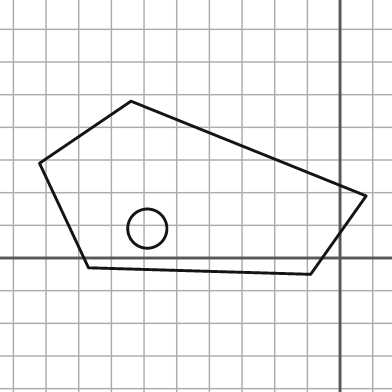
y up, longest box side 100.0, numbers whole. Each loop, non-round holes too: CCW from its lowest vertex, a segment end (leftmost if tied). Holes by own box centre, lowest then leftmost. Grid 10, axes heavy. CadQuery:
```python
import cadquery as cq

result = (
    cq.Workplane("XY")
    .moveTo(-9.0, -5.0)
    .lineTo(8.0, 19.0)
    .lineTo(-64.0, 48.0)
    .lineTo(-92.0, 29.0)
    .lineTo(-77.0, -3.0)
    .close()
    .moveTo(-59.0, 9.0)
    .circle(6.0)
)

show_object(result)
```